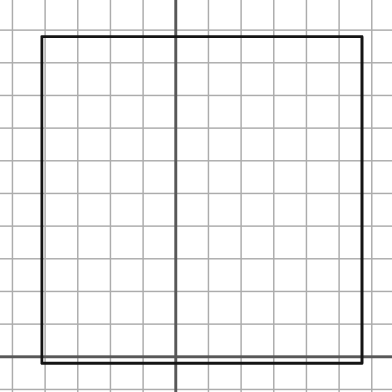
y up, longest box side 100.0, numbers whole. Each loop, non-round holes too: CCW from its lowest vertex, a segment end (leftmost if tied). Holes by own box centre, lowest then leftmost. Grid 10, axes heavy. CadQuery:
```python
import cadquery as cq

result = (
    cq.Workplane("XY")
    .moveTo(-41.0, -2.0)
    .lineTo(57.0, -2.0)
    .lineTo(57.0, 98.0)
    .lineTo(-41.0, 98.0)
    .close()
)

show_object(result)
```